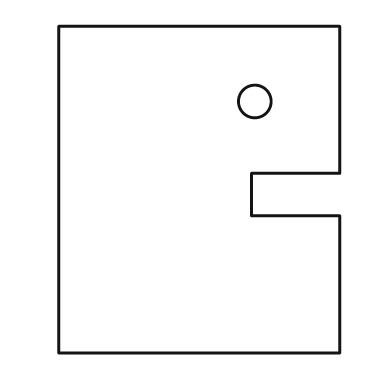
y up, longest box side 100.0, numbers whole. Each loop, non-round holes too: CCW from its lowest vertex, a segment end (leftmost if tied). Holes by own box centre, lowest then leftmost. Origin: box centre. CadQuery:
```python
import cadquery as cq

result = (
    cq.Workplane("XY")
    .moveTo(-43.0, -50.0)
    .lineTo(43.0, -50.0)
    .lineTo(43.0, -8.0)
    .lineTo(16.0, -8.0)
    .lineTo(16.0, 5.0)
    .lineTo(43.0, 5.0)
    .lineTo(43.0, 50.0)
    .lineTo(-43.0, 50.0)
    .close()
    .moveTo(17.0, 27.0)
    .circle(5.0)
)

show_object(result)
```